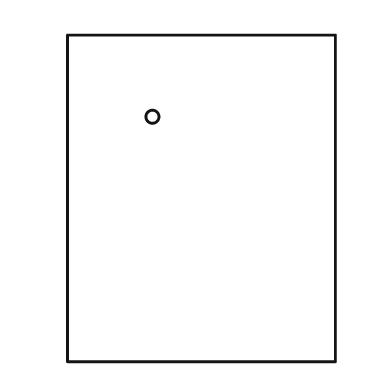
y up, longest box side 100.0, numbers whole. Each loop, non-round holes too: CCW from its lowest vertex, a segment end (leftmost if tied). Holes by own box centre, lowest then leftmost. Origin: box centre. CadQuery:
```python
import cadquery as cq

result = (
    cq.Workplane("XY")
    .moveTo(-41.0, -50.0)
    .lineTo(41.0, -50.0)
    .lineTo(41.0, 50.0)
    .lineTo(-41.0, 50.0)
    .close()
    .moveTo(-15.0, 25.0)
    .circle(2.0)
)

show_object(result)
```